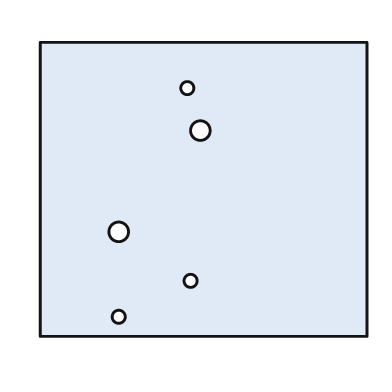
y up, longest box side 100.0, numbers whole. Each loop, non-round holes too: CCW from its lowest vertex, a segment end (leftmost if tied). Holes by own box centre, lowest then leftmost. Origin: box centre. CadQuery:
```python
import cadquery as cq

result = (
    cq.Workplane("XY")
    .moveTo(-50.0, -45.0)
    .lineTo(50.0, -45.0)
    .lineTo(50.0, 45.0)
    .lineTo(-50.0, 45.0)
    .close()
    .moveTo(-26.0, -39.0)
    .circle(2.0)
    .moveTo(-4.0, -28.0)
    .circle(2.0)
    .moveTo(-26.0, -13.0)
    .circle(3.0)
    .moveTo(-1.0, 18.0)
    .circle(3.0)
    .moveTo(-5.0, 31.0)
    .circle(2.0)
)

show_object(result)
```